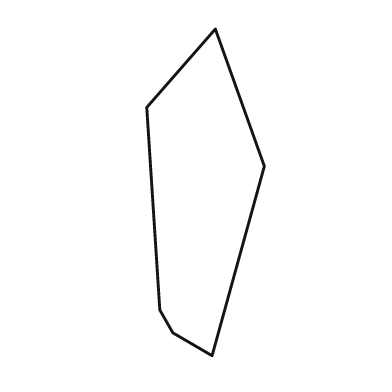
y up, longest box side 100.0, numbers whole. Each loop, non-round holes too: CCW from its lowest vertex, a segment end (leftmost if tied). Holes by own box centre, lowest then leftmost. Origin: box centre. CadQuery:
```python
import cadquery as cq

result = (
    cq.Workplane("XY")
    .moveTo(2.0, -50.0)
    .lineTo(18.0, 8.0)
    .lineTo(3.0, 50.0)
    .lineTo(-18.0, 26.0)
    .lineTo(-14.0, -36.0)
    .lineTo(-10.0, -43.0)
    .close()
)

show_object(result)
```